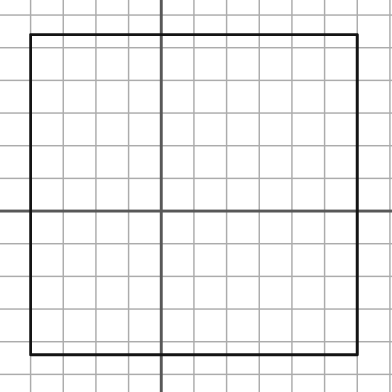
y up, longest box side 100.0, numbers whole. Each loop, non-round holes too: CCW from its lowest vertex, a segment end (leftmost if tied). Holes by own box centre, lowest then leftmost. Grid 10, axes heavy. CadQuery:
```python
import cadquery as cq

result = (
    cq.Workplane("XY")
    .moveTo(-40.0, -44.0)
    .lineTo(60.0, -44.0)
    .lineTo(60.0, 54.0)
    .lineTo(-40.0, 54.0)
    .close()
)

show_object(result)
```